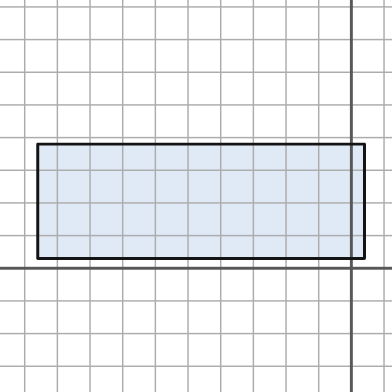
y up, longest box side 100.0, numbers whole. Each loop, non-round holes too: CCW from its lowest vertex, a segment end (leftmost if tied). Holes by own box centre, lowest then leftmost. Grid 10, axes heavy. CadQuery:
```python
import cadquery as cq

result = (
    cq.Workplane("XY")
    .moveTo(-96.0, 3.0)
    .lineTo(4.0, 3.0)
    .lineTo(4.0, 38.0)
    .lineTo(-96.0, 38.0)
    .close()
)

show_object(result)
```